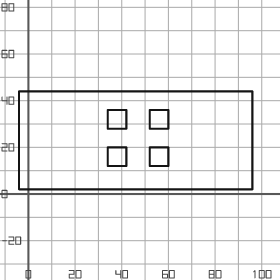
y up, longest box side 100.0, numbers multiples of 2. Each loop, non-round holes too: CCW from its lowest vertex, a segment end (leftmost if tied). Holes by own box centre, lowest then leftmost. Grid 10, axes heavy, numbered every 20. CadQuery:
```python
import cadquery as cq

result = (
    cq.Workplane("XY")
    .moveTo(-4.0, 2.0)
    .lineTo(96.0, 2.0)
    .lineTo(96.0, 44.0)
    .lineTo(-4.0, 44.0)
    .close()
    .moveTo(34.0, 12.0)
    .lineTo(42.0, 12.0)
    .lineTo(42.0, 20.0)
    .lineTo(34.0, 20.0)
    .close()
    .moveTo(52.0, 12.0)
    .lineTo(60.0, 12.0)
    .lineTo(60.0, 20.0)
    .lineTo(52.0, 20.0)
    .close()
    .moveTo(34.0, 28.0)
    .lineTo(42.0, 28.0)
    .lineTo(42.0, 36.0)
    .lineTo(34.0, 36.0)
    .close()
    .moveTo(52.0, 28.0)
    .lineTo(60.0, 28.0)
    .lineTo(60.0, 36.0)
    .lineTo(52.0, 36.0)
    .close()
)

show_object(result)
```